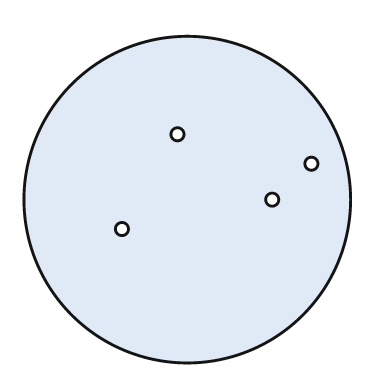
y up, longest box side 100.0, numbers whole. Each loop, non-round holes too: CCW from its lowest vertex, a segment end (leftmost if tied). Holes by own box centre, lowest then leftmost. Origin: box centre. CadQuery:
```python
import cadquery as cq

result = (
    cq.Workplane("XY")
    .moveTo(0.0, 0.0)
    .circle(50.0)
    .moveTo(-20.0, -9.0)
    .circle(2.0)
    .moveTo(26.0, 0.0)
    .circle(2.0)
    .moveTo(38.0, 11.0)
    .circle(2.0)
    .moveTo(-3.0, 20.0)
    .circle(2.0)
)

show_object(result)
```